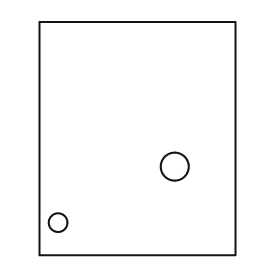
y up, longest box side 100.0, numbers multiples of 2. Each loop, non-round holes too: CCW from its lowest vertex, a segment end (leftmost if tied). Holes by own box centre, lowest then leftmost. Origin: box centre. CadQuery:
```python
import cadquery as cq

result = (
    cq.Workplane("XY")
    .moveTo(-42.0, -50.0)
    .lineTo(42.0, -50.0)
    .lineTo(42.0, 50.0)
    .lineTo(-42.0, 50.0)
    .close()
    .moveTo(-34.0, -36.0)
    .circle(4.0)
    .moveTo(16.0, -12.0)
    .circle(6.0)
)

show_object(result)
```